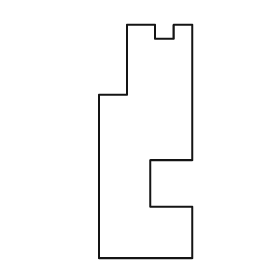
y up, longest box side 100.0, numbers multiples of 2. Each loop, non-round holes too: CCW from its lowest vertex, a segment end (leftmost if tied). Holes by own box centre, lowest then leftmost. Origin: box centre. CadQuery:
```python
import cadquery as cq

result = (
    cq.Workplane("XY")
    .moveTo(-20.0, -50.0)
    .lineTo(20.0, -50.0)
    .lineTo(20.0, -28.0)
    .lineTo(2.0, -28.0)
    .lineTo(2.0, -8.0)
    .lineTo(20.0, -8.0)
    .lineTo(20.0, 50.0)
    .lineTo(12.0, 50.0)
    .lineTo(12.0, 44.0)
    .lineTo(4.0, 44.0)
    .lineTo(4.0, 50.0)
    .lineTo(-8.0, 50.0)
    .lineTo(-8.0, 20.0)
    .lineTo(-20.0, 20.0)
    .close()
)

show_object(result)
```